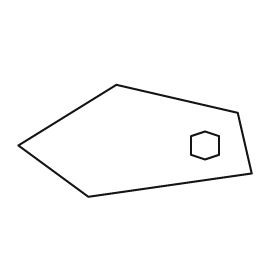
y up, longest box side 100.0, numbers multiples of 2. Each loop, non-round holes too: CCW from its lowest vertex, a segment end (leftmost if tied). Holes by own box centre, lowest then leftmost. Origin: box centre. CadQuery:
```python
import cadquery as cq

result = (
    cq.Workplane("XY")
    .moveTo(-20.0, -24.0)
    .lineTo(50.0, -14.0)
    .lineTo(44.0, 12.0)
    .lineTo(-8.0, 24.0)
    .lineTo(-50.0, -2.0)
    .close()
    .moveTo(30.0, -8.0)
    .lineTo(36.0, -6.0)
    .lineTo(36.0, 2.0)
    .lineTo(30.0, 4.0)
    .lineTo(24.0, 2.0)
    .lineTo(24.0, -6.0)
    .close()
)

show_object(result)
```